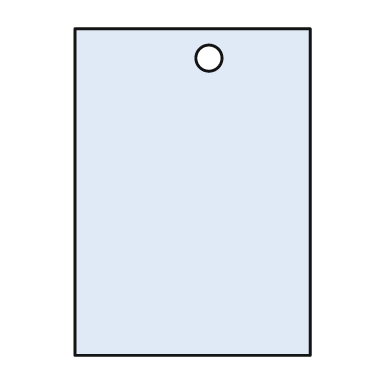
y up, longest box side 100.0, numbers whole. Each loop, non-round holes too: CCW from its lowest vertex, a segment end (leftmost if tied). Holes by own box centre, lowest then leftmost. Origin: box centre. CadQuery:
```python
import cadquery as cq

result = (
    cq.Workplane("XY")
    .moveTo(-36.0, -50.0)
    .lineTo(36.0, -50.0)
    .lineTo(36.0, 50.0)
    .lineTo(-36.0, 50.0)
    .close()
    .moveTo(5.0, 41.0)
    .circle(4.0)
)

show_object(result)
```